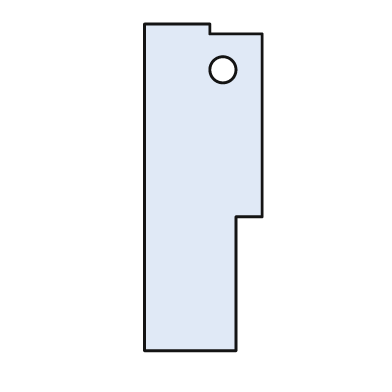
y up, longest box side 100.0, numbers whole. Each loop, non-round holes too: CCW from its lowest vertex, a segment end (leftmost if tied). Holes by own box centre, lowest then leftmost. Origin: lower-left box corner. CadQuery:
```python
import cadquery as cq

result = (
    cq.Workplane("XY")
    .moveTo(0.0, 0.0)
    .lineTo(28.0, 0.0)
    .lineTo(28.0, 41.0)
    .lineTo(36.0, 41.0)
    .lineTo(36.0, 97.0)
    .lineTo(20.0, 97.0)
    .lineTo(20.0, 100.0)
    .lineTo(0.0, 100.0)
    .close()
    .moveTo(24.0, 86.0)
    .circle(4.0)
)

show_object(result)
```